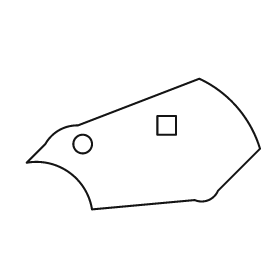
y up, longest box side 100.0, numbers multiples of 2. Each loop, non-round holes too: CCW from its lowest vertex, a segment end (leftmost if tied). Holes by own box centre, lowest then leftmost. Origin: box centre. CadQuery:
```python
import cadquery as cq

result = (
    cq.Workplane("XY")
    .moveTo(-22.0, -28.0)
    .lineTo(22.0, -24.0)
    .threePointArc((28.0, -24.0), (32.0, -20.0))
    .lineTo(50.0, -2.0)
    .threePointArc((40.0, 16.0), (24.0, 28.0))
    .lineTo(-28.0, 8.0)
    .threePointArc((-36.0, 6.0), (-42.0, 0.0))
    .lineTo(-50.0, -8.0)
    .threePointArc((-32.0, -12.0), (-22.0, -28.0))
    .close()
    .moveTo(-26.0, 0.0)
    .circle(4.0)
    .moveTo(6.0, 4.0)
    .lineTo(14.0, 4.0)
    .lineTo(14.0, 12.0)
    .lineTo(6.0, 12.0)
    .close()
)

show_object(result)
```